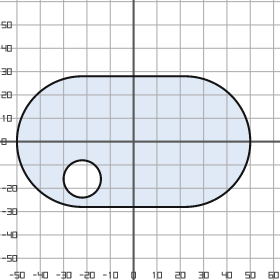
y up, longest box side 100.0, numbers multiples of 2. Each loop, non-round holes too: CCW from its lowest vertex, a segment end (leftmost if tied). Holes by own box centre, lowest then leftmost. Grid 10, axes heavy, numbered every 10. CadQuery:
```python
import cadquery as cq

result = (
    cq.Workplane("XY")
    .moveTo(-22.0, -28.0)
    .lineTo(22.0, -28.0)
    .threePointArc((50.0, 0.0), (22.0, 28.0))
    .lineTo(-22.0, 28.0)
    .threePointArc((-50.0, 0.0), (-22.0, -28.0))
    .close()
    .moveTo(-22.0, -16.0)
    .circle(8.0)
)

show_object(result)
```